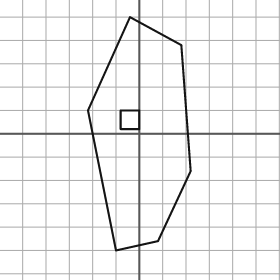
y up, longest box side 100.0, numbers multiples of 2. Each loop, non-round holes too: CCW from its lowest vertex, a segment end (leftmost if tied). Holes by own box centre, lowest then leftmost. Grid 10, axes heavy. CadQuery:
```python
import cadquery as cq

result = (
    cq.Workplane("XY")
    .moveTo(-10.0, -50.0)
    .lineTo(8.0, -46.0)
    .lineTo(22.0, -16.0)
    .lineTo(18.0, 38.0)
    .lineTo(-4.0, 50.0)
    .lineTo(-22.0, 10.0)
    .close()
    .moveTo(-8.0, 2.0)
    .lineTo(0.0, 2.0)
    .lineTo(0.0, 10.0)
    .lineTo(-8.0, 10.0)
    .close()
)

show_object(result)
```